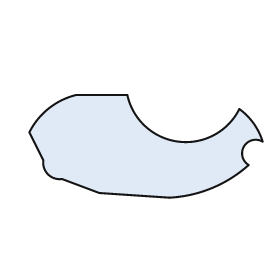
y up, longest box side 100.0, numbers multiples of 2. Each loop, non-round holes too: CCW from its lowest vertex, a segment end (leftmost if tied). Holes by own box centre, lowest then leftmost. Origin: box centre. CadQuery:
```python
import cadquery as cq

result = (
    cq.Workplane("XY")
    .moveTo(10.0, -22.0)
    .threePointArc((28.0, -18.0), (44.0, -8.0))
    .threePointArc((42.0, 0.0), (50.0, 2.0))
    .threePointArc((46.0, 10.0), (40.0, 16.0))
    .threePointArc((14.0, 2.0), (-8.0, 22.0))
    .lineTo(-30.0, 22.0)
    .threePointArc((-42.0, 16.0), (-50.0, 6.0))
    .lineTo(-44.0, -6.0)
    .threePointArc((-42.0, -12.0), (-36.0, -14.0))
    .lineTo(-20.0, -20.0)
    .close()
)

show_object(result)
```